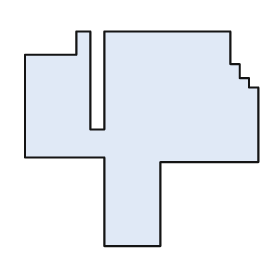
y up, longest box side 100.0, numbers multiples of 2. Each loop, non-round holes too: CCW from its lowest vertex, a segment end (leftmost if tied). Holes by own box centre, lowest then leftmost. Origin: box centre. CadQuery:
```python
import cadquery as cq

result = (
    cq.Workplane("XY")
    .moveTo(-16.0, -46.0)
    .lineTo(8.0, -46.0)
    .lineTo(8.0, -10.0)
    .lineTo(50.0, -10.0)
    .lineTo(50.0, 22.0)
    .lineTo(46.0, 22.0)
    .lineTo(46.0, 26.0)
    .lineTo(42.0, 26.0)
    .lineTo(42.0, 32.0)
    .lineTo(38.0, 32.0)
    .lineTo(38.0, 46.0)
    .lineTo(-16.0, 46.0)
    .lineTo(-16.0, 4.0)
    .lineTo(-22.0, 4.0)
    .lineTo(-22.0, 46.0)
    .lineTo(-28.0, 46.0)
    .lineTo(-28.0, 36.0)
    .lineTo(-50.0, 36.0)
    .lineTo(-50.0, -8.0)
    .lineTo(-16.0, -8.0)
    .close()
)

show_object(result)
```